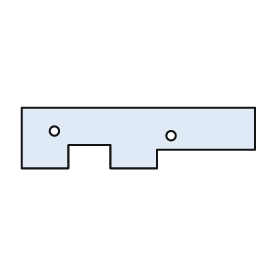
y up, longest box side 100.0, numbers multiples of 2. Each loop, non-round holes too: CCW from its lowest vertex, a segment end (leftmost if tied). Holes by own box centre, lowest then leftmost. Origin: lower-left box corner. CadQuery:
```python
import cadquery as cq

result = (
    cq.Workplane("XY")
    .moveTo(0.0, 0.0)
    .lineTo(20.0, 0.0)
    .lineTo(20.0, 10.0)
    .lineTo(38.0, 10.0)
    .lineTo(38.0, 0.0)
    .lineTo(58.0, 0.0)
    .lineTo(58.0, 8.0)
    .lineTo(100.0, 8.0)
    .lineTo(100.0, 26.0)
    .lineTo(0.0, 26.0)
    .close()
    .moveTo(64.0, 14.0)
    .circle(2.0)
    .moveTo(14.0, 16.0)
    .circle(2.0)
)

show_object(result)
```